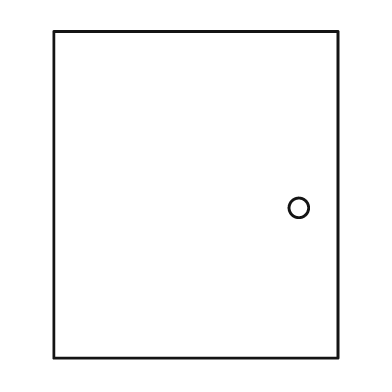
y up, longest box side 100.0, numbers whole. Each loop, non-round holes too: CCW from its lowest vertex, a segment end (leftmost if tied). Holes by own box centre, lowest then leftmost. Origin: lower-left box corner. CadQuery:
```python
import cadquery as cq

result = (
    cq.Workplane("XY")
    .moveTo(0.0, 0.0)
    .lineTo(87.0, 0.0)
    .lineTo(87.0, 100.0)
    .lineTo(0.0, 100.0)
    .close()
    .moveTo(75.0, 46.0)
    .circle(3.0)
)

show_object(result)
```